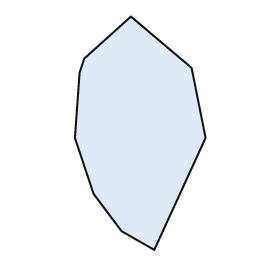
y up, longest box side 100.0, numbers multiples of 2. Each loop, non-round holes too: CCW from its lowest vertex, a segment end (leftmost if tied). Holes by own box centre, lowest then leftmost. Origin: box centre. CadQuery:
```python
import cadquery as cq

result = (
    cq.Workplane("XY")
    .moveTo(6.0, -50.0)
    .lineTo(28.0, -2.0)
    .lineTo(22.0, 28.0)
    .lineTo(-4.0, 50.0)
    .lineTo(-24.0, 32.0)
    .lineTo(-26.0, 26.0)
    .lineTo(-28.0, -2.0)
    .lineTo(-20.0, -26.0)
    .lineTo(-8.0, -42.0)
    .close()
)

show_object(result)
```